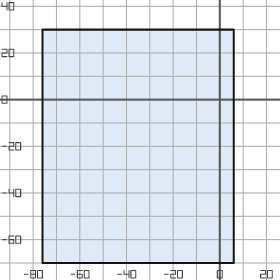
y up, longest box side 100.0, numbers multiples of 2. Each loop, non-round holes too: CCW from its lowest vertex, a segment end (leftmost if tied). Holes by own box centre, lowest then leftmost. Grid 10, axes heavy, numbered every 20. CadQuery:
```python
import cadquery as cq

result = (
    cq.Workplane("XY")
    .moveTo(-76.0, -70.0)
    .lineTo(6.0, -70.0)
    .lineTo(6.0, 30.0)
    .lineTo(-76.0, 30.0)
    .close()
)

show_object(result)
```